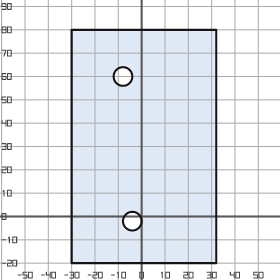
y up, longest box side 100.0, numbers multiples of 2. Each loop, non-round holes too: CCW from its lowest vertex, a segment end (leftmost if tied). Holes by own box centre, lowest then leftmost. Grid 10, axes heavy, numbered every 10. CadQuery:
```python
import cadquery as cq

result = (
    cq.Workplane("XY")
    .moveTo(-30.0, -20.0)
    .lineTo(32.0, -20.0)
    .lineTo(32.0, 80.0)
    .lineTo(-30.0, 80.0)
    .close()
    .moveTo(-4.0, -2.0)
    .circle(4.0)
    .moveTo(-8.0, 60.0)
    .circle(4.0)
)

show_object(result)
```